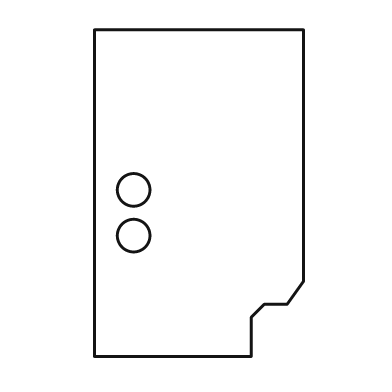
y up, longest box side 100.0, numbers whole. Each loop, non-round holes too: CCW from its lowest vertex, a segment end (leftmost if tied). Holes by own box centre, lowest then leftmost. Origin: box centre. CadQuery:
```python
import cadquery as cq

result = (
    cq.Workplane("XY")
    .moveTo(-32.0, -50.0)
    .lineTo(16.0, -50.0)
    .lineTo(16.0, -38.0)
    .lineTo(20.0, -34.0)
    .lineTo(27.0, -34.0)
    .lineTo(32.0, -27.0)
    .lineTo(32.0, 50.0)
    .lineTo(-32.0, 50.0)
    .close()
    .moveTo(-20.0, -13.0)
    .circle(5.0)
    .moveTo(-20.0, 1.0)
    .circle(5.0)
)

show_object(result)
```